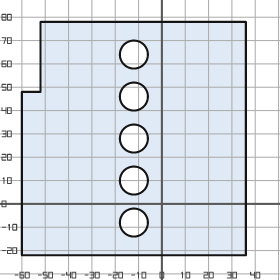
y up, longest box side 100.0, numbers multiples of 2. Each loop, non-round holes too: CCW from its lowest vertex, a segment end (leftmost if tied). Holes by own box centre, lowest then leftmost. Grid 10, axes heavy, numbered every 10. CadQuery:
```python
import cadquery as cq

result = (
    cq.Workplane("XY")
    .moveTo(-60.0, -22.0)
    .lineTo(36.0, -22.0)
    .lineTo(36.0, 78.0)
    .lineTo(-52.0, 78.0)
    .lineTo(-52.0, 48.0)
    .lineTo(-60.0, 48.0)
    .close()
    .moveTo(-12.0, -8.0)
    .circle(6.0)
    .moveTo(-12.0, 10.0)
    .circle(6.0)
    .moveTo(-12.0, 28.0)
    .circle(6.0)
    .moveTo(-12.0, 46.0)
    .circle(6.0)
    .moveTo(-12.0, 64.0)
    .circle(6.0)
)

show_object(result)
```